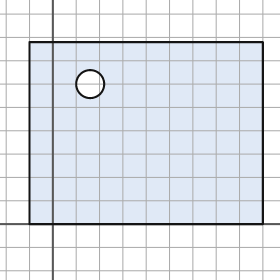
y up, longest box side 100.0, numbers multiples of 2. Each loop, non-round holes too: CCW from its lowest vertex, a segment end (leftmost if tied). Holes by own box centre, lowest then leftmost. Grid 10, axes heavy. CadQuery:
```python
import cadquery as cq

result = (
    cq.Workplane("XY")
    .moveTo(-10.0, 0.0)
    .lineTo(90.0, 0.0)
    .lineTo(90.0, 78.0)
    .lineTo(-10.0, 78.0)
    .close()
    .moveTo(16.0, 60.0)
    .circle(6.0)
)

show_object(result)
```